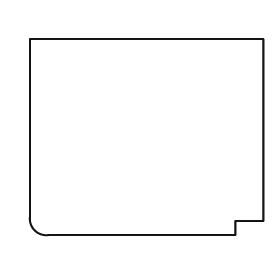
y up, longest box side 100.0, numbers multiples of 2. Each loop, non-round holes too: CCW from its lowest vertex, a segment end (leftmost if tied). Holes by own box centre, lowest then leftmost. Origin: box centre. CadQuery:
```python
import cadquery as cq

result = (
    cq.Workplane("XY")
    .moveTo(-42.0, -42.0)
    .lineTo(38.0, -42.0)
    .lineTo(38.0, -36.0)
    .lineTo(50.0, -36.0)
    .lineTo(50.0, 42.0)
    .lineTo(-50.0, 42.0)
    .lineTo(-50.0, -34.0)
    .threePointArc((-48.0, -40.0), (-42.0, -42.0))
    .close()
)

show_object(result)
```